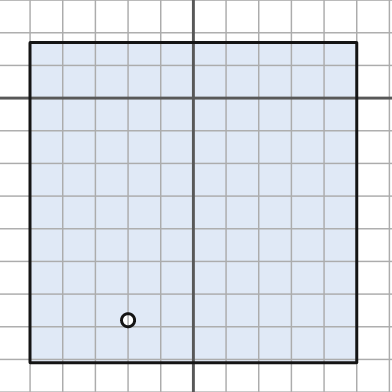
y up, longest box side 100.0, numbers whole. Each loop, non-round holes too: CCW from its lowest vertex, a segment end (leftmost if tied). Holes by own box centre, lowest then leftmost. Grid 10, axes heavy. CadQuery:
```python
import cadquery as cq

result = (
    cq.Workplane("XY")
    .moveTo(-50.0, -81.0)
    .lineTo(50.0, -81.0)
    .lineTo(50.0, 17.0)
    .lineTo(-50.0, 17.0)
    .close()
    .moveTo(-20.0, -68.0)
    .circle(2.0)
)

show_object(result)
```